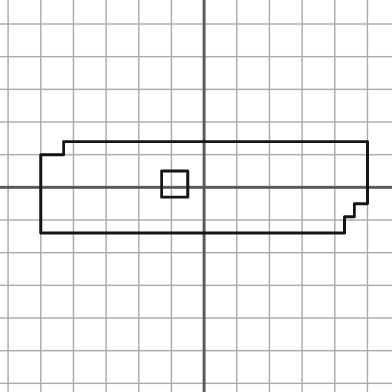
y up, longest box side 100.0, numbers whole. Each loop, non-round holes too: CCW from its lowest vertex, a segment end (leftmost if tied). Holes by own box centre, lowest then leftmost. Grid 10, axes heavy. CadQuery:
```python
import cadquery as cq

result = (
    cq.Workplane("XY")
    .moveTo(-50.0, -14.0)
    .lineTo(43.0, -14.0)
    .lineTo(43.0, -9.0)
    .lineTo(46.0, -9.0)
    .lineTo(46.0, -5.0)
    .lineTo(50.0, -5.0)
    .lineTo(50.0, 14.0)
    .lineTo(-43.0, 14.0)
    .lineTo(-43.0, 10.0)
    .lineTo(-50.0, 10.0)
    .close()
    .moveTo(-13.0, -3.0)
    .lineTo(-5.0, -3.0)
    .lineTo(-5.0, 5.0)
    .lineTo(-13.0, 5.0)
    .close()
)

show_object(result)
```